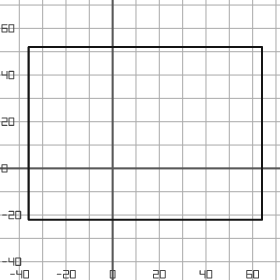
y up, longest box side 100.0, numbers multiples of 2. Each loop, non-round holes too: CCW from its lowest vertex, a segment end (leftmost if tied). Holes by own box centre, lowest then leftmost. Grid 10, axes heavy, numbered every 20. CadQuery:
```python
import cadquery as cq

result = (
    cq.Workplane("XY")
    .moveTo(-36.0, -22.0)
    .lineTo(64.0, -22.0)
    .lineTo(64.0, 52.0)
    .lineTo(-36.0, 52.0)
    .close()
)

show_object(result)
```